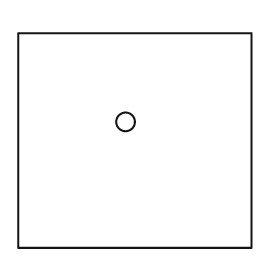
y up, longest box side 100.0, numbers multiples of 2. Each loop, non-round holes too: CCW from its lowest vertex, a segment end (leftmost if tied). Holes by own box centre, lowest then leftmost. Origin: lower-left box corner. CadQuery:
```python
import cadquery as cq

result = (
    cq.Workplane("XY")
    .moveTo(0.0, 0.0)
    .lineTo(100.0, 0.0)
    .lineTo(100.0, 92.0)
    .lineTo(0.0, 92.0)
    .close()
    .moveTo(46.0, 54.0)
    .circle(4.0)
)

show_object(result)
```